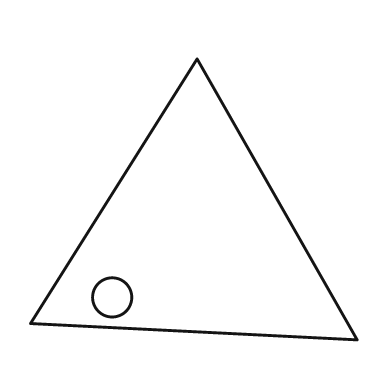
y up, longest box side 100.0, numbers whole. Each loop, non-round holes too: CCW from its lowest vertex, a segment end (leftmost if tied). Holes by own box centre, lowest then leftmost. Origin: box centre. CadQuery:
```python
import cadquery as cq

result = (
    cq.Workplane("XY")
    .moveTo(50.0, -43.0)
    .lineTo(1.0, 43.0)
    .lineTo(-50.0, -38.0)
    .close()
    .moveTo(-25.0, -30.0)
    .circle(6.0)
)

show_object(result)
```